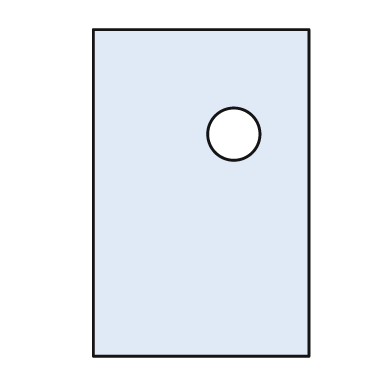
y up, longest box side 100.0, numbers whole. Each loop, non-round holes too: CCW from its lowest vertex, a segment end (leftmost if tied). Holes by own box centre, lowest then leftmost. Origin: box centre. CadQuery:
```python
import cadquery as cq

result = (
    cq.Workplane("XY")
    .moveTo(-33.0, -50.0)
    .lineTo(33.0, -50.0)
    .lineTo(33.0, 50.0)
    .lineTo(-33.0, 50.0)
    .close()
    .moveTo(10.0, 18.0)
    .circle(8.0)
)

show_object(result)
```